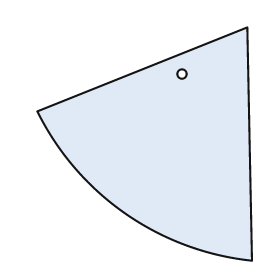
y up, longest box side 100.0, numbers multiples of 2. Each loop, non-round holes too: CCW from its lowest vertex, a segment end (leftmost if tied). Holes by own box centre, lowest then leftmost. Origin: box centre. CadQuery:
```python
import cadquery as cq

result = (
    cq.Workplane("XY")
    .moveTo(46.0, -50.0)
    .lineTo(44.0, 50.0)
    .lineTo(-46.0, 14.0)
    .threePointArc((-8.0, -30.0), (46.0, -50.0))
    .close()
    .moveTo(16.0, 30.0)
    .circle(2.0)
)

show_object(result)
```